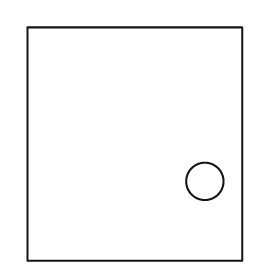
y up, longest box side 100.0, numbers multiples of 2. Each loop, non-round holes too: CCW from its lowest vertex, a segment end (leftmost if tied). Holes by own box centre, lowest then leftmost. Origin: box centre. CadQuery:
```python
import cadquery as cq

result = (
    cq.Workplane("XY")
    .moveTo(-46.0, -50.0)
    .lineTo(46.0, -50.0)
    .lineTo(46.0, 50.0)
    .lineTo(-46.0, 50.0)
    .close()
    .moveTo(30.0, -16.0)
    .circle(8.0)
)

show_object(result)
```